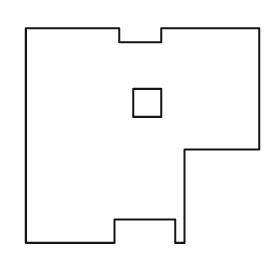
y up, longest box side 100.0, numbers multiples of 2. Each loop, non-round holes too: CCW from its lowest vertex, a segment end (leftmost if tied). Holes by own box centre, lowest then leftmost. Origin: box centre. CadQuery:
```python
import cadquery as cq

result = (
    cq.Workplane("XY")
    .moveTo(-50.0, -46.0)
    .lineTo(-12.0, -46.0)
    .lineTo(-12.0, -36.0)
    .lineTo(14.0, -36.0)
    .lineTo(14.0, -46.0)
    .lineTo(18.0, -46.0)
    .lineTo(18.0, -6.0)
    .lineTo(50.0, -6.0)
    .lineTo(50.0, 46.0)
    .lineTo(8.0, 46.0)
    .lineTo(8.0, 40.0)
    .lineTo(-10.0, 40.0)
    .lineTo(-10.0, 46.0)
    .lineTo(-50.0, 46.0)
    .close()
    .moveTo(-4.0, 8.0)
    .lineTo(8.0, 8.0)
    .lineTo(8.0, 20.0)
    .lineTo(-4.0, 20.0)
    .close()
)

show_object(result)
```